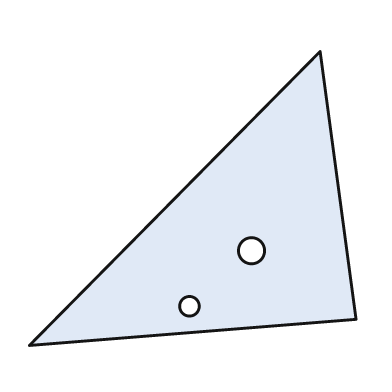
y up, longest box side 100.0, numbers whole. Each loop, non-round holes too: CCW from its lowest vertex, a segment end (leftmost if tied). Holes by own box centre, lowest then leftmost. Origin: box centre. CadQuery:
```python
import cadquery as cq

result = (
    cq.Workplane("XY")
    .moveTo(-50.0, -45.0)
    .lineTo(50.0, -37.0)
    .lineTo(39.0, 45.0)
    .close()
    .moveTo(-1.0, -33.0)
    .circle(3.0)
    .moveTo(18.0, -16.0)
    .circle(4.0)
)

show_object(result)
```